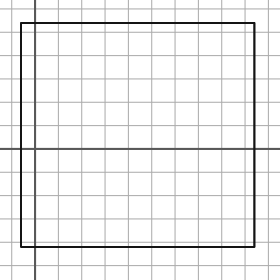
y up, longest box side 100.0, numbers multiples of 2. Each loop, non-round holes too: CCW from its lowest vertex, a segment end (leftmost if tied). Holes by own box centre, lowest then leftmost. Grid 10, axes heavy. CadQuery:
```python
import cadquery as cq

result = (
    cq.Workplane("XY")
    .moveTo(-6.0, -42.0)
    .lineTo(94.0, -42.0)
    .lineTo(94.0, 54.0)
    .lineTo(-6.0, 54.0)
    .close()
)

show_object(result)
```